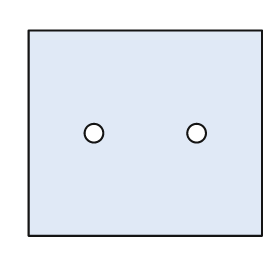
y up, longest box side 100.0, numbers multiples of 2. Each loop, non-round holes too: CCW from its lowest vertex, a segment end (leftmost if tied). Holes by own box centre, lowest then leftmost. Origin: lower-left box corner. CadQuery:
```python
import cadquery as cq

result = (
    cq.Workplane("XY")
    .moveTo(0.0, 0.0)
    .lineTo(100.0, 0.0)
    .lineTo(100.0, 88.0)
    .lineTo(0.0, 88.0)
    .close()
    .moveTo(28.0, 44.0)
    .circle(4.0)
    .moveTo(72.0, 44.0)
    .circle(4.0)
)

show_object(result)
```